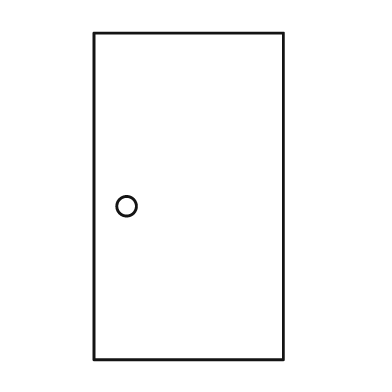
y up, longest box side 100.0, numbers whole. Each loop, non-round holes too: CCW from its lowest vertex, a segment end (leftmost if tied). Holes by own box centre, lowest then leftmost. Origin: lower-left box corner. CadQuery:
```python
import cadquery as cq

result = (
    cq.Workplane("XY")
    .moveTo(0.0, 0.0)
    .lineTo(58.0, 0.0)
    .lineTo(58.0, 100.0)
    .lineTo(0.0, 100.0)
    .close()
    .moveTo(10.0, 47.0)
    .circle(3.0)
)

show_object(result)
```